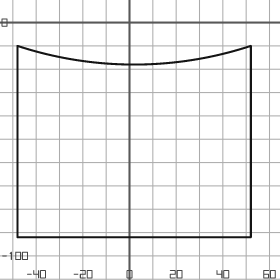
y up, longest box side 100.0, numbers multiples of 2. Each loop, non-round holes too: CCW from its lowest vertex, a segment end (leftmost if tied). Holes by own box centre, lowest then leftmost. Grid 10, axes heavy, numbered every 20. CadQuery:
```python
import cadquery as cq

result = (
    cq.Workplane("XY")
    .moveTo(-48.0, -92.0)
    .lineTo(52.0, -92.0)
    .lineTo(52.0, -10.0)
    .threePointArc((2.0, -18.0), (-48.0, -10.0))
    .close()
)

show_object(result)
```